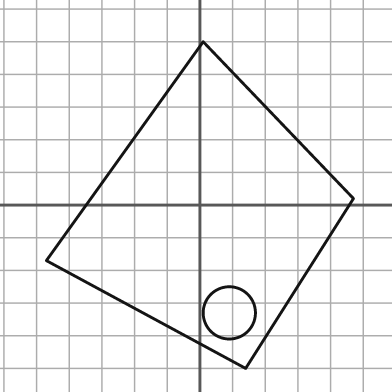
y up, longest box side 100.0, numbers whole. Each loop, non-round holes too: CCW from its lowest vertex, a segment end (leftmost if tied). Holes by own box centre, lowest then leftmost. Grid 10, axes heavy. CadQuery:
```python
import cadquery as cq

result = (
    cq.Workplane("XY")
    .moveTo(14.0, -50.0)
    .lineTo(47.0, 2.0)
    .lineTo(1.0, 50.0)
    .lineTo(-47.0, -17.0)
    .close()
    .moveTo(9.0, -33.0)
    .circle(8.0)
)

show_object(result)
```